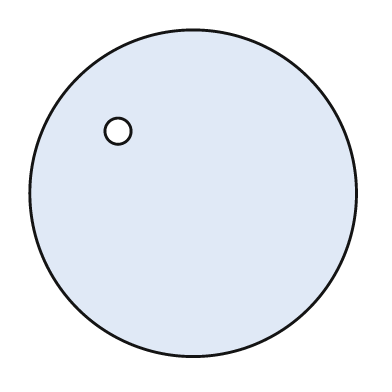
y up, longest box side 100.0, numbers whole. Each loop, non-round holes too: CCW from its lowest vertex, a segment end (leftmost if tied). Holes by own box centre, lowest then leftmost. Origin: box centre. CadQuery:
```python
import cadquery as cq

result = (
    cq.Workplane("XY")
    .moveTo(0.0, 0.0)
    .circle(50.0)
    .moveTo(-23.0, 19.0)
    .circle(4.0)
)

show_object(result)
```